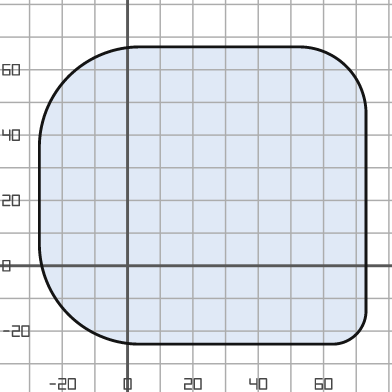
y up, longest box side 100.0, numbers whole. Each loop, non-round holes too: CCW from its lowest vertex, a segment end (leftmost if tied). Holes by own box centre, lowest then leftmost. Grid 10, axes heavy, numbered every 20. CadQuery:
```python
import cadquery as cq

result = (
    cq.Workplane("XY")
    .moveTo(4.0, -24.0)
    .lineTo(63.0, -24.0)
    .threePointArc((70.0, -21.0), (73.0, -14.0))
    .lineTo(73.0, 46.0)
    .threePointArc((67.0, 61.0), (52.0, 67.0))
    .lineTo(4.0, 67.0)
    .threePointArc((-18.0, 58.0), (-27.0, 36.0))
    .lineTo(-27.0, 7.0)
    .threePointArc((-18.0, -15.0), (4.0, -24.0))
    .close()
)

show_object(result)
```